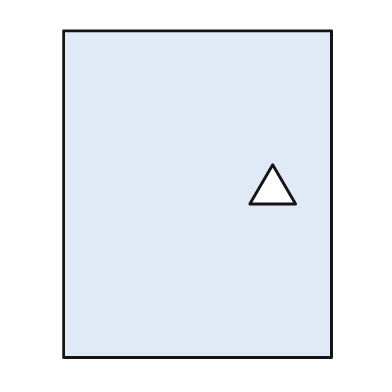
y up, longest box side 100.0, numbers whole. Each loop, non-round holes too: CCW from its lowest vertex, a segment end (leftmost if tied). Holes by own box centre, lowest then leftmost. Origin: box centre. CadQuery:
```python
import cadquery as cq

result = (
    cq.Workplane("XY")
    .moveTo(-41.0, -50.0)
    .lineTo(41.0, -50.0)
    .lineTo(41.0, 50.0)
    .lineTo(-41.0, 50.0)
    .close()
    .moveTo(16.0, -3.0)
    .lineTo(30.0, -3.0)
    .lineTo(23.0, 9.0)
    .close()
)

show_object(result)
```